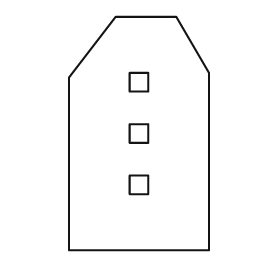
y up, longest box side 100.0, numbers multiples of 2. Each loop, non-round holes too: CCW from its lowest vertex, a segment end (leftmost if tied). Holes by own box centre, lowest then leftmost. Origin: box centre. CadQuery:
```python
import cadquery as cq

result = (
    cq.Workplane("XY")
    .moveTo(-30.0, -50.0)
    .lineTo(30.0, -50.0)
    .lineTo(30.0, 26.0)
    .lineTo(16.0, 50.0)
    .lineTo(-10.0, 50.0)
    .lineTo(-30.0, 24.0)
    .close()
    .moveTo(-4.0, -26.0)
    .lineTo(4.0, -26.0)
    .lineTo(4.0, -18.0)
    .lineTo(-4.0, -18.0)
    .close()
    .moveTo(-4.0, -4.0)
    .lineTo(4.0, -4.0)
    .lineTo(4.0, 4.0)
    .lineTo(-4.0, 4.0)
    .close()
    .moveTo(-4.0, 18.0)
    .lineTo(4.0, 18.0)
    .lineTo(4.0, 26.0)
    .lineTo(-4.0, 26.0)
    .close()
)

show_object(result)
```